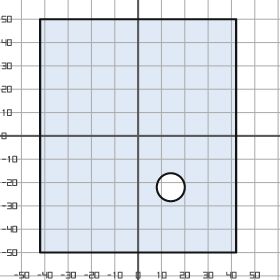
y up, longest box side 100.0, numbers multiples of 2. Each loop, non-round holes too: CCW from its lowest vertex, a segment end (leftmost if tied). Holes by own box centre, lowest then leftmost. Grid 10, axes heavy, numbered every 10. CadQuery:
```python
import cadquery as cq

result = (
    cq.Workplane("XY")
    .moveTo(-42.0, -50.0)
    .lineTo(42.0, -50.0)
    .lineTo(42.0, 50.0)
    .lineTo(-42.0, 50.0)
    .close()
    .moveTo(14.0, -22.0)
    .circle(6.0)
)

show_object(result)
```